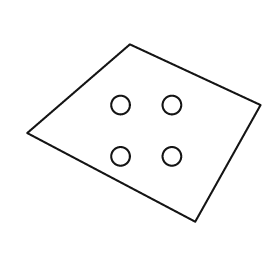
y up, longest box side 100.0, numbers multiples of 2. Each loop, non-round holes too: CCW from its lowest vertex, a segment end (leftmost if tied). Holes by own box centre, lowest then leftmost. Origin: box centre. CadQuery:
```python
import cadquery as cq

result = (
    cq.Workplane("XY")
    .moveTo(22.0, -38.0)
    .lineTo(50.0, 12.0)
    .lineTo(-6.0, 38.0)
    .lineTo(-50.0, 0.0)
    .close()
    .moveTo(-10.0, -10.0)
    .circle(4.0)
    .moveTo(12.0, -10.0)
    .circle(4.0)
    .moveTo(-10.0, 12.0)
    .circle(4.0)
    .moveTo(12.0, 12.0)
    .circle(4.0)
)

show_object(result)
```